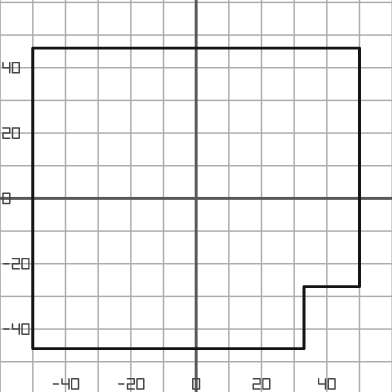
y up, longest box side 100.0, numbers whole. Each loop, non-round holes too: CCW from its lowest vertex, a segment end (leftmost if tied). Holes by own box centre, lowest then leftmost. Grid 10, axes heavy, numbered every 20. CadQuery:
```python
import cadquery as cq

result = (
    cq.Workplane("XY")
    .moveTo(-50.0, -46.0)
    .lineTo(33.0, -46.0)
    .lineTo(33.0, -27.0)
    .lineTo(50.0, -27.0)
    .lineTo(50.0, 46.0)
    .lineTo(-50.0, 46.0)
    .close()
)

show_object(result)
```